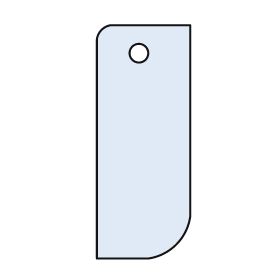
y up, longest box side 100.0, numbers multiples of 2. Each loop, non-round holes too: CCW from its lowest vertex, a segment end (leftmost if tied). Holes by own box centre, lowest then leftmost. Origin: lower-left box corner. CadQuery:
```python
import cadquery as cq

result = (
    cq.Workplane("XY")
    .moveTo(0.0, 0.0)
    .lineTo(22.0, 0.0)
    .threePointArc((34.0, 6.0), (40.0, 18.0))
    .lineTo(40.0, 100.0)
    .lineTo(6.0, 100.0)
    .threePointArc((2.0, 98.0), (0.0, 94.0))
    .close()
    .moveTo(18.0, 88.0)
    .circle(4.0)
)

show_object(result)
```